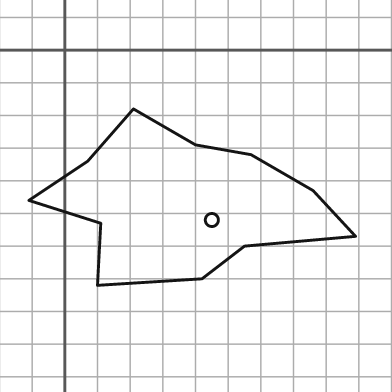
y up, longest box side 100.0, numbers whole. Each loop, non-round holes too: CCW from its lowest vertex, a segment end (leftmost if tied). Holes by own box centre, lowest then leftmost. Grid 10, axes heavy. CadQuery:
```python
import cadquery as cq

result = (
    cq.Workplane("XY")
    .moveTo(10.0, -72.0)
    .lineTo(42.0, -70.0)
    .lineTo(55.0, -60.0)
    .lineTo(89.0, -57.0)
    .lineTo(76.0, -43.0)
    .lineTo(57.0, -32.0)
    .lineTo(40.0, -29.0)
    .lineTo(21.0, -18.0)
    .lineTo(7.0, -34.0)
    .lineTo(-11.0, -46.0)
    .lineTo(11.0, -53.0)
    .close()
    .moveTo(45.0, -52.0)
    .circle(2.0)
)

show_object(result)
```